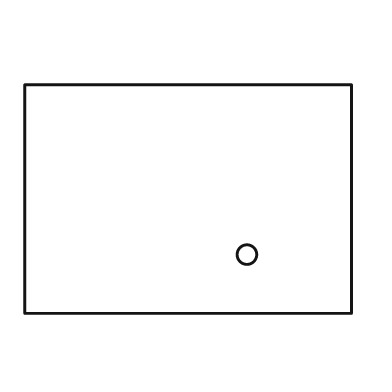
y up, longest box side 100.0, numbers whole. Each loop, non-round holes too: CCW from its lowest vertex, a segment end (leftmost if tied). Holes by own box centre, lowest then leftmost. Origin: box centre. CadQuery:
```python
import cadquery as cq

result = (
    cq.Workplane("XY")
    .moveTo(-50.0, -35.0)
    .lineTo(50.0, -35.0)
    .lineTo(50.0, 35.0)
    .lineTo(-50.0, 35.0)
    .close()
    .moveTo(18.0, -17.0)
    .circle(3.0)
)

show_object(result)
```